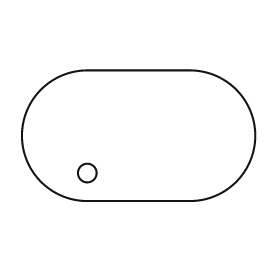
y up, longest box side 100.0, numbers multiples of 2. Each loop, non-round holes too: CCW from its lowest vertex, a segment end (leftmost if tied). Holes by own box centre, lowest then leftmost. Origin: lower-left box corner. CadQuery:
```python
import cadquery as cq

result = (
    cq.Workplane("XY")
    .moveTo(28.0, 0.0)
    .lineTo(72.0, 0.0)
    .threePointArc((100.0, 28.0), (72.0, 56.0))
    .lineTo(28.0, 56.0)
    .threePointArc((0.0, 28.0), (28.0, 0.0))
    .close()
    .moveTo(28.0, 12.0)
    .circle(4.0)
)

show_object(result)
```